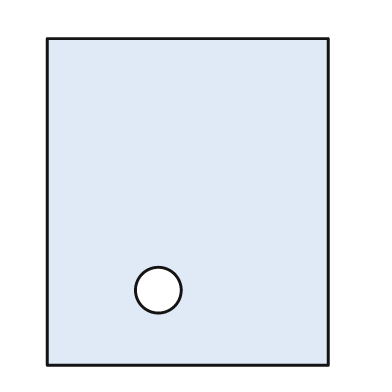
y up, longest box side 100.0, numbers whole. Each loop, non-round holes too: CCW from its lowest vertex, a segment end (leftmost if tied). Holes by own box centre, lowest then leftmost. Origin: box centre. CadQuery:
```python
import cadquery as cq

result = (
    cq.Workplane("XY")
    .moveTo(-43.0, -50.0)
    .lineTo(43.0, -50.0)
    .lineTo(43.0, 50.0)
    .lineTo(-43.0, 50.0)
    .close()
    .moveTo(-9.0, -27.0)
    .circle(7.0)
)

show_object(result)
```